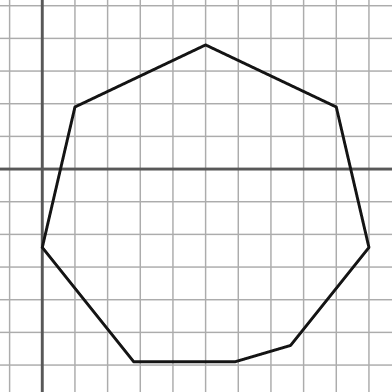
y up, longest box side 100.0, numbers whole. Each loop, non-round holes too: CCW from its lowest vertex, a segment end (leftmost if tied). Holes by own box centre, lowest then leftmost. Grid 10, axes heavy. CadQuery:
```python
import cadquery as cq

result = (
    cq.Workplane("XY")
    .moveTo(28.0, -59.0)
    .lineTo(59.0, -59.0)
    .lineTo(76.0, -54.0)
    .lineTo(100.0, -24.0)
    .lineTo(90.0, 19.0)
    .lineTo(50.0, 38.0)
    .lineTo(10.0, 19.0)
    .lineTo(0.0, -24.0)
    .close()
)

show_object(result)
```